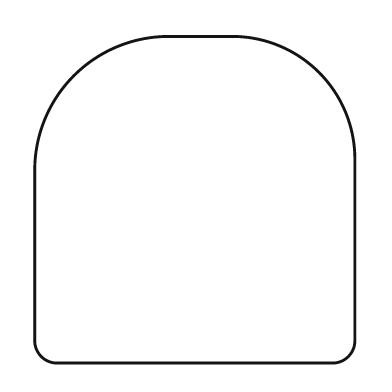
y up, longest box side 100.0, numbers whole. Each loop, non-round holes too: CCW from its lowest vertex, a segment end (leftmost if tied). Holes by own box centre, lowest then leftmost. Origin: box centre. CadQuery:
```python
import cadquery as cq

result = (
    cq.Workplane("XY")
    .moveTo(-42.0, -50.0)
    .lineTo(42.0, -50.0)
    .threePointArc((47.0, -48.0), (49.0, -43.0))
    .lineTo(49.0, 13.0)
    .threePointArc((38.0, 39.0), (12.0, 50.0))
    .lineTo(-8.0, 50.0)
    .threePointArc((-37.0, 38.0), (-49.0, 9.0))
    .lineTo(-49.0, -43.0)
    .threePointArc((-47.0, -48.0), (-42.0, -50.0))
    .close()
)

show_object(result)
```